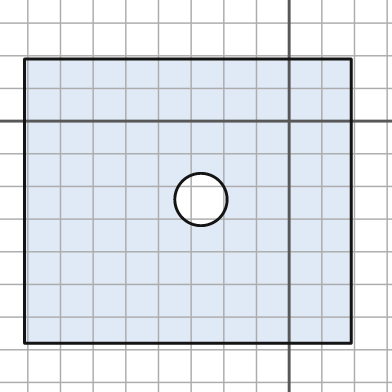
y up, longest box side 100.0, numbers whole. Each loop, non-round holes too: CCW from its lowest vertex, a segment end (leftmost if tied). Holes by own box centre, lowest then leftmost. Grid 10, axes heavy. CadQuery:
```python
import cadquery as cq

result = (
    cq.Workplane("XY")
    .moveTo(-81.0, -68.0)
    .lineTo(19.0, -68.0)
    .lineTo(19.0, 19.0)
    .lineTo(-81.0, 19.0)
    .close()
    .moveTo(-27.0, -24.0)
    .circle(8.0)
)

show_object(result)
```